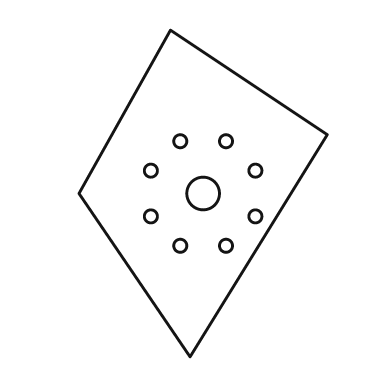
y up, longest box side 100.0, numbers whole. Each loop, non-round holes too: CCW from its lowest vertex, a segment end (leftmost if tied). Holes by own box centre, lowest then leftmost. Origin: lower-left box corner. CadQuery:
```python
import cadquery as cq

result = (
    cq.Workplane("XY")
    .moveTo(34.0, 0.0)
    .lineTo(76.0, 68.0)
    .lineTo(28.0, 100.0)
    .lineTo(0.0, 50.0)
    .close()
    .moveTo(31.0, 34.0)
    .circle(2.0)
    .moveTo(45.0, 34.0)
    .circle(2.0)
    .moveTo(22.0, 43.0)
    .circle(2.0)
    .moveTo(54.0, 43.0)
    .circle(2.0)
    .moveTo(38.0, 50.0)
    .circle(5.0)
    .moveTo(22.0, 57.0)
    .circle(2.0)
    .moveTo(54.0, 57.0)
    .circle(2.0)
    .moveTo(31.0, 66.0)
    .circle(2.0)
    .moveTo(45.0, 66.0)
    .circle(2.0)
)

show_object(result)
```